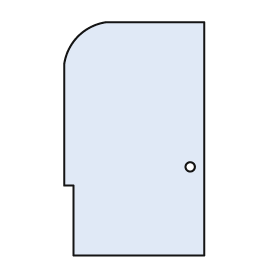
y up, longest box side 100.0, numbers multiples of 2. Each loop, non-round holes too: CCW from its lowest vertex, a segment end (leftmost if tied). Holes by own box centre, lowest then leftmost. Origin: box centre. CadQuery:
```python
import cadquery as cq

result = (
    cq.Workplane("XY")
    .moveTo(-26.0, -50.0)
    .lineTo(30.0, -50.0)
    .lineTo(30.0, 50.0)
    .lineTo(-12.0, 50.0)
    .threePointArc((-24.0, 44.0), (-30.0, 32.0))
    .lineTo(-30.0, -20.0)
    .lineTo(-26.0, -20.0)
    .close()
    .moveTo(24.0, -12.0)
    .circle(2.0)
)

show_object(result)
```